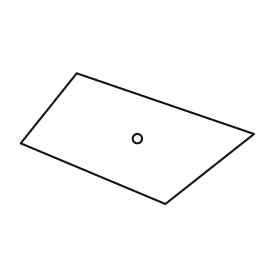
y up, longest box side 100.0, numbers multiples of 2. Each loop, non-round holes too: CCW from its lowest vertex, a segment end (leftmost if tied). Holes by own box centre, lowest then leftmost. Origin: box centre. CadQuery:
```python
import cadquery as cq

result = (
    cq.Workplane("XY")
    .moveTo(12.0, -28.0)
    .lineTo(50.0, 2.0)
    .lineTo(-26.0, 28.0)
    .lineTo(-50.0, -2.0)
    .close()
    .moveTo(0.0, 0.0)
    .circle(2.0)
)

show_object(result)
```